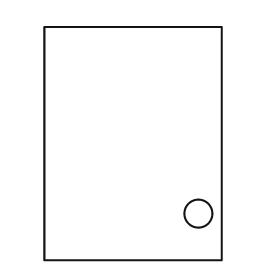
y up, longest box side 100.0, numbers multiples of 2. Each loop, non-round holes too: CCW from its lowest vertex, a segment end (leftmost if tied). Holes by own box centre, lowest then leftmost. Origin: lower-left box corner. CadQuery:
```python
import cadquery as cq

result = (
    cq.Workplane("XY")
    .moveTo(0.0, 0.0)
    .lineTo(76.0, 0.0)
    .lineTo(76.0, 100.0)
    .lineTo(0.0, 100.0)
    .close()
    .moveTo(66.0, 20.0)
    .circle(6.0)
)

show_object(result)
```